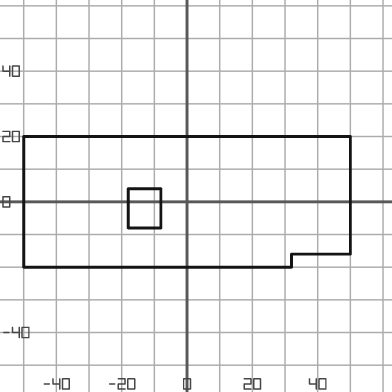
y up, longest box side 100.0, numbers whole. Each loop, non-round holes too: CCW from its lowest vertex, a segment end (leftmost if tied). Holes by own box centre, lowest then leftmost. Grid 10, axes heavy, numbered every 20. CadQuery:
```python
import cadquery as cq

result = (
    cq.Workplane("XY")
    .moveTo(-50.0, -20.0)
    .lineTo(32.0, -20.0)
    .lineTo(32.0, -16.0)
    .lineTo(50.0, -16.0)
    .lineTo(50.0, 20.0)
    .lineTo(-50.0, 20.0)
    .close()
    .moveTo(-18.0, -8.0)
    .lineTo(-8.0, -8.0)
    .lineTo(-8.0, 4.0)
    .lineTo(-18.0, 4.0)
    .close()
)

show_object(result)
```